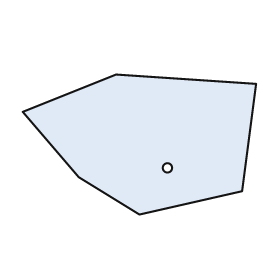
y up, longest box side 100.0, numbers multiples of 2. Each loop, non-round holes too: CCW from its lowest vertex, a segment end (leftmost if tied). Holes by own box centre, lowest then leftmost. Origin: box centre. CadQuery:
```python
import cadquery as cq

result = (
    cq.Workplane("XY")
    .moveTo(0.0, -30.0)
    .lineTo(44.0, -20.0)
    .lineTo(50.0, 26.0)
    .lineTo(-10.0, 30.0)
    .lineTo(-50.0, 14.0)
    .lineTo(-26.0, -14.0)
    .close()
    .moveTo(12.0, -10.0)
    .circle(2.0)
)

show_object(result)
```